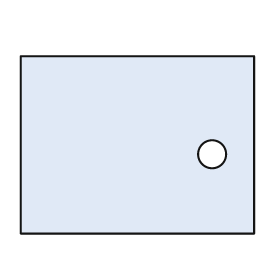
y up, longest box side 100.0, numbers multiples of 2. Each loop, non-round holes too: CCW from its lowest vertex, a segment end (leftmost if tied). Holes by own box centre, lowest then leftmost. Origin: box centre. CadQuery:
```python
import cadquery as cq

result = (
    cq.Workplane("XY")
    .moveTo(-50.0, -38.0)
    .lineTo(50.0, -38.0)
    .lineTo(50.0, 38.0)
    .lineTo(-50.0, 38.0)
    .close()
    .moveTo(32.0, -4.0)
    .circle(6.0)
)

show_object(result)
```